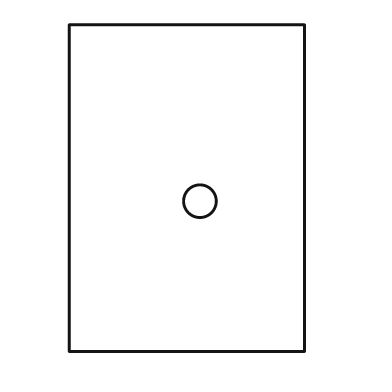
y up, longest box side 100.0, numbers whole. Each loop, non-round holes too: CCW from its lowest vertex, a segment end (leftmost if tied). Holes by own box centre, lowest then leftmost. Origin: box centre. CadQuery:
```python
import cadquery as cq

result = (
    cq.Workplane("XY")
    .moveTo(-36.0, -50.0)
    .lineTo(36.0, -50.0)
    .lineTo(36.0, 50.0)
    .lineTo(-36.0, 50.0)
    .close()
    .moveTo(4.0, -4.0)
    .circle(5.0)
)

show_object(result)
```